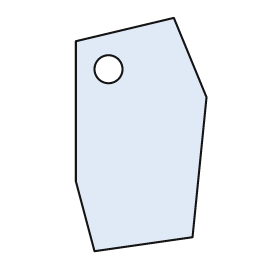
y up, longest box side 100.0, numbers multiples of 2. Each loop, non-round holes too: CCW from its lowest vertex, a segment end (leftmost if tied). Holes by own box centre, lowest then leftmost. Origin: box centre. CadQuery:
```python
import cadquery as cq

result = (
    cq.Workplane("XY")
    .moveTo(-20.0, -50.0)
    .lineTo(22.0, -44.0)
    .lineTo(28.0, 16.0)
    .lineTo(14.0, 50.0)
    .lineTo(-28.0, 40.0)
    .lineTo(-28.0, -20.0)
    .close()
    .moveTo(-14.0, 28.0)
    .circle(6.0)
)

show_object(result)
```